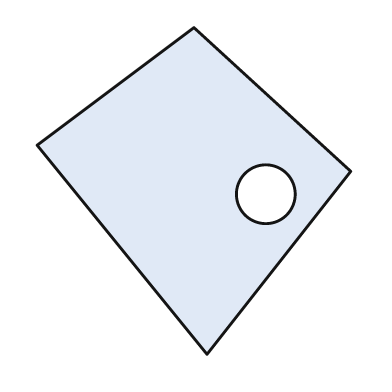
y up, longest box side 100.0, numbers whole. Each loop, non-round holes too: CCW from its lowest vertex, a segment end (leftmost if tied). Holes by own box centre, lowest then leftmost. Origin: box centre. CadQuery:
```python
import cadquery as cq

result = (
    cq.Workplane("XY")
    .moveTo(4.0, -50.0)
    .lineTo(48.0, 6.0)
    .lineTo(0.0, 50.0)
    .lineTo(-48.0, 14.0)
    .close()
    .moveTo(22.0, -1.0)
    .circle(9.0)
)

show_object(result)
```